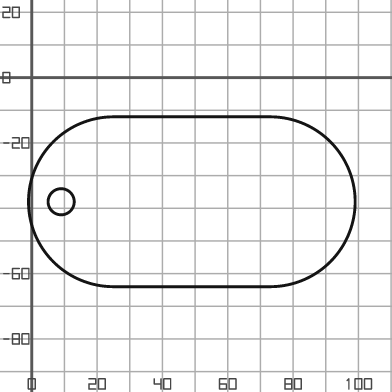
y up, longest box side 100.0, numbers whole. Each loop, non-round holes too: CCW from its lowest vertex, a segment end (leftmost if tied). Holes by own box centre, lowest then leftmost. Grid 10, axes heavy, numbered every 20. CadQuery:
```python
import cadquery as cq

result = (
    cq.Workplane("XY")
    .moveTo(25.0, -64.0)
    .lineTo(73.0, -64.0)
    .threePointArc((99.0, -38.0), (73.0, -12.0))
    .lineTo(25.0, -12.0)
    .threePointArc((-1.0, -38.0), (25.0, -64.0))
    .close()
    .moveTo(9.0, -38.0)
    .circle(4.0)
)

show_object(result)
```